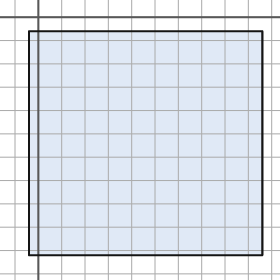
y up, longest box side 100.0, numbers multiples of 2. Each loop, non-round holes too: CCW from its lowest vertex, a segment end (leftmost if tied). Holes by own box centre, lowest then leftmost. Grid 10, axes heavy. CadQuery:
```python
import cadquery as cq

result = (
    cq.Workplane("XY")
    .moveTo(-4.0, -102.0)
    .lineTo(96.0, -102.0)
    .lineTo(96.0, -6.0)
    .lineTo(-4.0, -6.0)
    .close()
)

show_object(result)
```